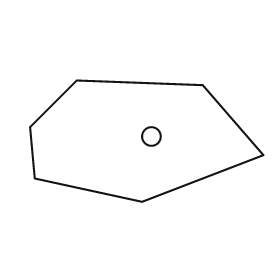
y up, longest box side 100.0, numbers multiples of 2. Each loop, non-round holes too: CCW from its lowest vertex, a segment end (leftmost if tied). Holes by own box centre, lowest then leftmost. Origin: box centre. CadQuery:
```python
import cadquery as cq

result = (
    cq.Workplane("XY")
    .moveTo(-2.0, -26.0)
    .lineTo(50.0, -6.0)
    .lineTo(24.0, 24.0)
    .lineTo(-30.0, 26.0)
    .lineTo(-50.0, 6.0)
    .lineTo(-48.0, -16.0)
    .close()
    .moveTo(2.0, 2.0)
    .circle(4.0)
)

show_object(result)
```